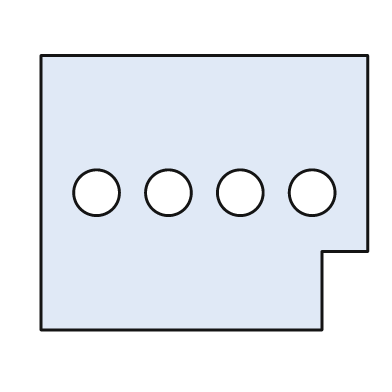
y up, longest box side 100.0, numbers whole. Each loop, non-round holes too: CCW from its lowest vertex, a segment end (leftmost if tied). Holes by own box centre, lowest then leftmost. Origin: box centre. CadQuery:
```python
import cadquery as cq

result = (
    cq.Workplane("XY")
    .moveTo(-50.0, -42.0)
    .lineTo(36.0, -42.0)
    .lineTo(36.0, -18.0)
    .lineTo(50.0, -18.0)
    .lineTo(50.0, 42.0)
    .lineTo(-50.0, 42.0)
    .close()
    .moveTo(-33.0, 0.0)
    .circle(7.0)
    .moveTo(-11.0, 0.0)
    .circle(7.0)
    .moveTo(11.0, 0.0)
    .circle(7.0)
    .moveTo(33.0, 0.0)
    .circle(7.0)
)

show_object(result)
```